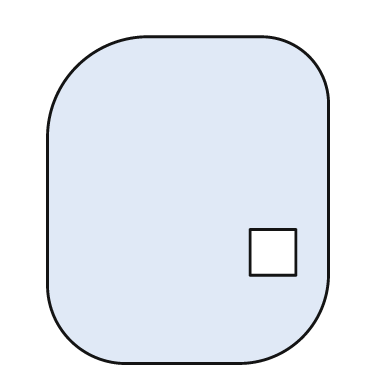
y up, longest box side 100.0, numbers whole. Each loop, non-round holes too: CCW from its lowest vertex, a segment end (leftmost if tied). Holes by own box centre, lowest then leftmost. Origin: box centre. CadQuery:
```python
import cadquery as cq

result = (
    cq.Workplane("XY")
    .moveTo(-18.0, -50.0)
    .lineTo(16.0, -50.0)
    .threePointArc((35.0, -42.0), (43.0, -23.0))
    .lineTo(43.0, 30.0)
    .threePointArc((37.0, 44.0), (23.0, 50.0))
    .lineTo(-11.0, 50.0)
    .threePointArc((-34.0, 41.0), (-43.0, 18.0))
    .lineTo(-43.0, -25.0)
    .threePointArc((-36.0, -43.0), (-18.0, -50.0))
    .close()
    .moveTo(19.0, -23.0)
    .lineTo(33.0, -23.0)
    .lineTo(33.0, -9.0)
    .lineTo(19.0, -9.0)
    .close()
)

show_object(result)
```